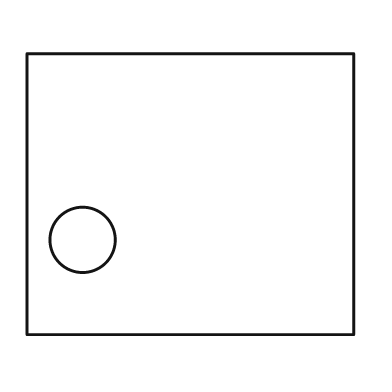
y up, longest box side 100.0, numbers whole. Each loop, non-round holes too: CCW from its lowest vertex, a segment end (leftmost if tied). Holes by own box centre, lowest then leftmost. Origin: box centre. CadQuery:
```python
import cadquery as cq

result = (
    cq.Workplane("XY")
    .moveTo(-50.0, -43.0)
    .lineTo(50.0, -43.0)
    .lineTo(50.0, 43.0)
    .lineTo(-50.0, 43.0)
    .close()
    .moveTo(-33.0, -14.0)
    .circle(10.0)
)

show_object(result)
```